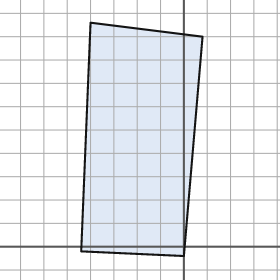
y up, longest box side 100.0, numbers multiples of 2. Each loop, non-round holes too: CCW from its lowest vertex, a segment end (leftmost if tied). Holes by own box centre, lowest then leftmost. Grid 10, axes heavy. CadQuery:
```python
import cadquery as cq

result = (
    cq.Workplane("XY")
    .moveTo(0.0, -4.0)
    .lineTo(8.0, 90.0)
    .lineTo(-40.0, 96.0)
    .lineTo(-44.0, -2.0)
    .close()
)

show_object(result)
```